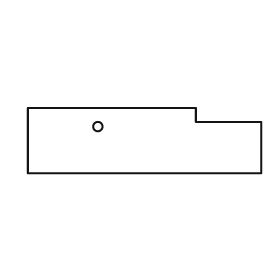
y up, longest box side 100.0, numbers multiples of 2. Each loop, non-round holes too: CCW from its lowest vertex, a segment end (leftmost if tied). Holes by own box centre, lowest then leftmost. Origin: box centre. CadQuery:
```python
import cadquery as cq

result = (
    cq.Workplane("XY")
    .moveTo(-50.0, -14.0)
    .lineTo(50.0, -14.0)
    .lineTo(50.0, 8.0)
    .lineTo(22.0, 8.0)
    .lineTo(22.0, 14.0)
    .lineTo(-50.0, 14.0)
    .close()
    .moveTo(-20.0, 6.0)
    .circle(2.0)
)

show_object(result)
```